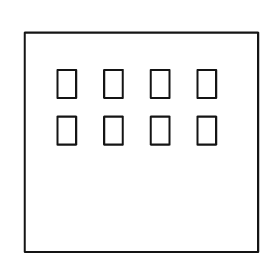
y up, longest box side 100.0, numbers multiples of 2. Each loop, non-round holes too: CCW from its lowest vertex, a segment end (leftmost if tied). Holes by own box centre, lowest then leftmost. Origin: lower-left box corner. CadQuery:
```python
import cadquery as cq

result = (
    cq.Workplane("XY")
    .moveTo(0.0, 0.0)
    .lineTo(100.0, 0.0)
    .lineTo(100.0, 94.0)
    .lineTo(0.0, 94.0)
    .close()
    .moveTo(14.0, 46.0)
    .lineTo(22.0, 46.0)
    .lineTo(22.0, 58.0)
    .lineTo(14.0, 58.0)
    .close()
    .moveTo(34.0, 46.0)
    .lineTo(42.0, 46.0)
    .lineTo(42.0, 58.0)
    .lineTo(34.0, 58.0)
    .close()
    .moveTo(54.0, 46.0)
    .lineTo(62.0, 46.0)
    .lineTo(62.0, 58.0)
    .lineTo(54.0, 58.0)
    .close()
    .moveTo(74.0, 46.0)
    .lineTo(82.0, 46.0)
    .lineTo(82.0, 58.0)
    .lineTo(74.0, 58.0)
    .close()
    .moveTo(14.0, 66.0)
    .lineTo(22.0, 66.0)
    .lineTo(22.0, 78.0)
    .lineTo(14.0, 78.0)
    .close()
    .moveTo(34.0, 66.0)
    .lineTo(42.0, 66.0)
    .lineTo(42.0, 78.0)
    .lineTo(34.0, 78.0)
    .close()
    .moveTo(54.0, 66.0)
    .lineTo(62.0, 66.0)
    .lineTo(62.0, 78.0)
    .lineTo(54.0, 78.0)
    .close()
    .moveTo(74.0, 66.0)
    .lineTo(82.0, 66.0)
    .lineTo(82.0, 78.0)
    .lineTo(74.0, 78.0)
    .close()
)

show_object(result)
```